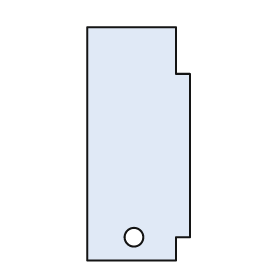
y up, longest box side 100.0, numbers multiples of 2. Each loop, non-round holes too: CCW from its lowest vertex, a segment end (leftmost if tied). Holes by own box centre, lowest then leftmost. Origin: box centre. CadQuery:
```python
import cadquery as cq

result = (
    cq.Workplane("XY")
    .moveTo(-22.0, -50.0)
    .lineTo(16.0, -50.0)
    .lineTo(16.0, -40.0)
    .lineTo(22.0, -40.0)
    .lineTo(22.0, 30.0)
    .lineTo(16.0, 30.0)
    .lineTo(16.0, 50.0)
    .lineTo(-22.0, 50.0)
    .close()
    .moveTo(-2.0, -40.0)
    .circle(4.0)
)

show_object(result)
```